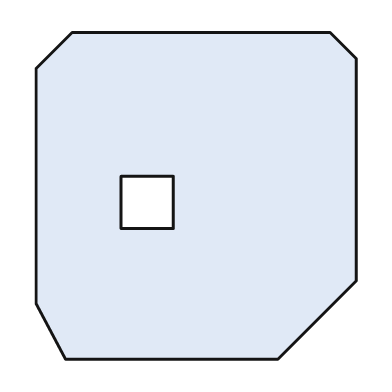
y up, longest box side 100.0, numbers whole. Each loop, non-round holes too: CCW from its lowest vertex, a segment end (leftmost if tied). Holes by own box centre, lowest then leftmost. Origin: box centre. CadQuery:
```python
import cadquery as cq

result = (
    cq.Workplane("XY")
    .moveTo(-40.0, -50.0)
    .lineTo(25.0, -50.0)
    .lineTo(49.0, -26.0)
    .lineTo(49.0, 42.0)
    .lineTo(41.0, 50.0)
    .lineTo(-38.0, 50.0)
    .lineTo(-49.0, 39.0)
    .lineTo(-49.0, -33.0)
    .close()
    .moveTo(-23.0, -10.0)
    .lineTo(-7.0, -10.0)
    .lineTo(-7.0, 6.0)
    .lineTo(-23.0, 6.0)
    .close()
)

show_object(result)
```